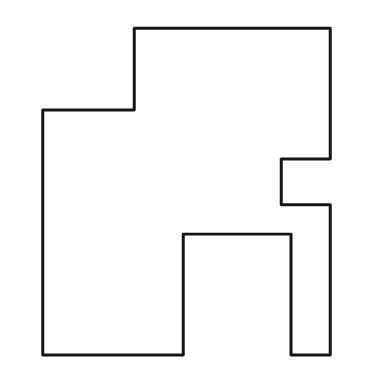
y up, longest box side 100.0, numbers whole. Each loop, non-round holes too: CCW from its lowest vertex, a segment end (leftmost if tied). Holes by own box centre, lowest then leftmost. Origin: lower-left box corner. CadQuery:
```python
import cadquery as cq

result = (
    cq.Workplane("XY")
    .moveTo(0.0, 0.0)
    .lineTo(43.0, 0.0)
    .lineTo(43.0, 37.0)
    .lineTo(76.0, 37.0)
    .lineTo(76.0, 0.0)
    .lineTo(88.0, 0.0)
    .lineTo(88.0, 46.0)
    .lineTo(73.0, 46.0)
    .lineTo(73.0, 60.0)
    .lineTo(88.0, 60.0)
    .lineTo(88.0, 100.0)
    .lineTo(28.0, 100.0)
    .lineTo(28.0, 75.0)
    .lineTo(0.0, 75.0)
    .close()
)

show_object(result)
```